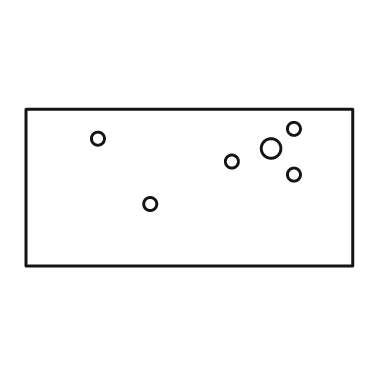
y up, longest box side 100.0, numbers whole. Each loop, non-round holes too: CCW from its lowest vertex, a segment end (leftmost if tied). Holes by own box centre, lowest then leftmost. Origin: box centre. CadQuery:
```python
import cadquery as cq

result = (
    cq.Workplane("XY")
    .moveTo(-50.0, -24.0)
    .lineTo(50.0, -24.0)
    .lineTo(50.0, 24.0)
    .lineTo(-50.0, 24.0)
    .close()
    .moveTo(-12.0, -5.0)
    .circle(2.0)
    .moveTo(32.0, 4.0)
    .circle(2.0)
    .moveTo(13.0, 8.0)
    .circle(2.0)
    .moveTo(25.0, 12.0)
    .circle(3.0)
    .moveTo(-28.0, 15.0)
    .circle(2.0)
    .moveTo(32.0, 18.0)
    .circle(2.0)
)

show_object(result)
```